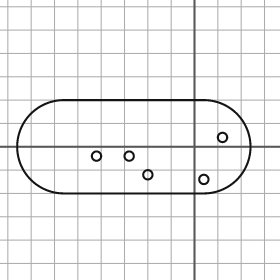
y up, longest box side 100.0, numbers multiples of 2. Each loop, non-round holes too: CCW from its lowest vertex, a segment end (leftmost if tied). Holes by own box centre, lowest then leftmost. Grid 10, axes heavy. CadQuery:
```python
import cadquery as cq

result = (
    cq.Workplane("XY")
    .moveTo(-56.0, -20.0)
    .lineTo(4.0, -20.0)
    .threePointArc((24.0, 0.0), (4.0, 20.0))
    .lineTo(-56.0, 20.0)
    .threePointArc((-76.0, 0.0), (-56.0, -20.0))
    .close()
    .moveTo(4.0, -14.0)
    .circle(2.0)
    .moveTo(-20.0, -12.0)
    .circle(2.0)
    .moveTo(-42.0, -4.0)
    .circle(2.0)
    .moveTo(-28.0, -4.0)
    .circle(2.0)
    .moveTo(12.0, 4.0)
    .circle(2.0)
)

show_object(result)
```